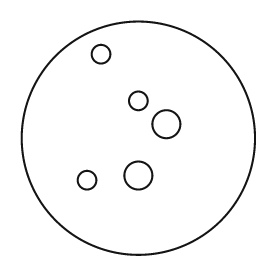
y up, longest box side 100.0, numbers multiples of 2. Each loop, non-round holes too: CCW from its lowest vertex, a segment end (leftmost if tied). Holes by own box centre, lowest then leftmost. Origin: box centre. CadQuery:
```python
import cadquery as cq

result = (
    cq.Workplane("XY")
    .moveTo(0.0, 0.0)
    .circle(50.0)
    .moveTo(-22.0, -18.0)
    .circle(4.0)
    .moveTo(0.0, -16.0)
    .circle(6.0)
    .moveTo(12.0, 6.0)
    .circle(6.0)
    .moveTo(0.0, 16.0)
    .circle(4.0)
    .moveTo(-16.0, 36.0)
    .circle(4.0)
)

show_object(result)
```